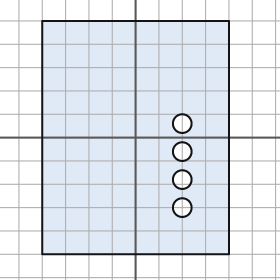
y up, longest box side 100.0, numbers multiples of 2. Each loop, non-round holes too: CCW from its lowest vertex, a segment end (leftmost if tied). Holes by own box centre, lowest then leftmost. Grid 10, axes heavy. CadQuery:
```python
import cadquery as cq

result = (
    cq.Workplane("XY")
    .moveTo(-40.0, -50.0)
    .lineTo(40.0, -50.0)
    .lineTo(40.0, 50.0)
    .lineTo(-40.0, 50.0)
    .close()
    .moveTo(20.0, -30.0)
    .circle(4.0)
    .moveTo(20.0, -18.0)
    .circle(4.0)
    .moveTo(20.0, -6.0)
    .circle(4.0)
    .moveTo(20.0, 6.0)
    .circle(4.0)
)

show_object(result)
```